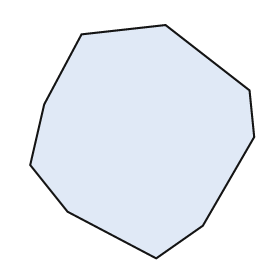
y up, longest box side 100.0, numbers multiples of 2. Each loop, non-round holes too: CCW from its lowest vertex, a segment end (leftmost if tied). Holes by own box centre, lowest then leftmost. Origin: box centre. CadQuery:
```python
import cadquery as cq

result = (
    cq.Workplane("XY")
    .moveTo(6.0, -50.0)
    .lineTo(26.0, -36.0)
    .lineTo(48.0, 2.0)
    .lineTo(46.0, 22.0)
    .lineTo(10.0, 50.0)
    .lineTo(-26.0, 46.0)
    .lineTo(-42.0, 16.0)
    .lineTo(-48.0, -10.0)
    .lineTo(-32.0, -30.0)
    .close()
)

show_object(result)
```